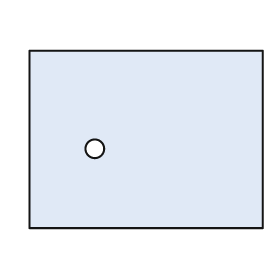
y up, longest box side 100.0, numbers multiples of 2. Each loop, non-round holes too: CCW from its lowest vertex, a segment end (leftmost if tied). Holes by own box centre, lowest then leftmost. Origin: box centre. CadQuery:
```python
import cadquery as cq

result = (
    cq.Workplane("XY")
    .moveTo(-50.0, -38.0)
    .lineTo(50.0, -38.0)
    .lineTo(50.0, 38.0)
    .lineTo(-50.0, 38.0)
    .close()
    .moveTo(-22.0, -4.0)
    .circle(4.0)
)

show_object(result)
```